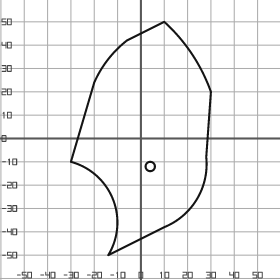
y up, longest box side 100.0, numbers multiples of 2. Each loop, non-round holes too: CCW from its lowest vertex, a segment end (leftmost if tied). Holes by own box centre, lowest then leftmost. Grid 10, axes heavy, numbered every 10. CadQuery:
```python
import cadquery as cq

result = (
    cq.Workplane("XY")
    .moveTo(-14.0, -50.0)
    .lineTo(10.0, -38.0)
    .threePointArc((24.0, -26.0), (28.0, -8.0))
    .lineTo(30.0, 20.0)
    .threePointArc((22.0, 36.0), (10.0, 50.0))
    .lineTo(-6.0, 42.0)
    .threePointArc((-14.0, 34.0), (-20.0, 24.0))
    .lineTo(-30.0, -10.0)
    .threePointArc((-12.0, -26.0), (-14.0, -50.0))
    .close()
    .moveTo(4.0, -12.0)
    .circle(2.0)
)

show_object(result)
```